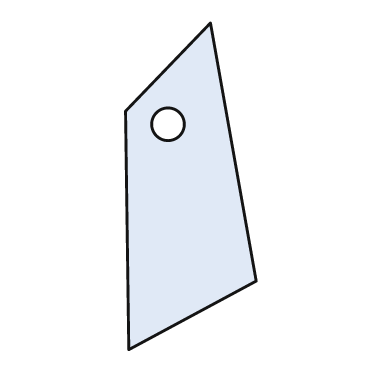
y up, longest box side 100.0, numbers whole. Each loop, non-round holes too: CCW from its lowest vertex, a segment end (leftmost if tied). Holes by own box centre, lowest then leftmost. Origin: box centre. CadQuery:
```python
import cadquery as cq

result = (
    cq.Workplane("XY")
    .moveTo(-19.0, -50.0)
    .lineTo(20.0, -29.0)
    .lineTo(6.0, 50.0)
    .lineTo(-20.0, 23.0)
    .close()
    .moveTo(-7.0, 19.0)
    .circle(5.0)
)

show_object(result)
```